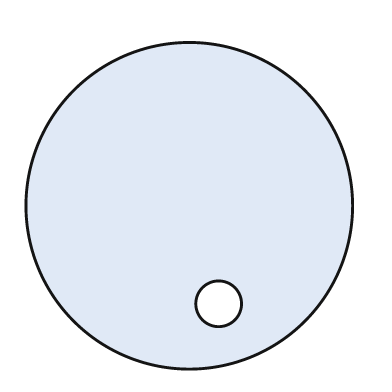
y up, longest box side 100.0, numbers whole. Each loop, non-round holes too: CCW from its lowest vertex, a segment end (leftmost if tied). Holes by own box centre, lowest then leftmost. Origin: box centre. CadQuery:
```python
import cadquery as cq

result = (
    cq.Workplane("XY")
    .moveTo(0.0, 0.0)
    .circle(50.0)
    .moveTo(9.0, -30.0)
    .circle(7.0)
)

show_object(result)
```